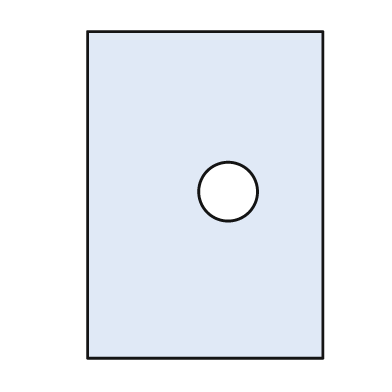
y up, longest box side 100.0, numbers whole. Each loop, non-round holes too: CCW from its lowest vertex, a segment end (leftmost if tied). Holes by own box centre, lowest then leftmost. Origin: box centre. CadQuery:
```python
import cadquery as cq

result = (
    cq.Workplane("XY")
    .moveTo(-36.0, -50.0)
    .lineTo(36.0, -50.0)
    .lineTo(36.0, 50.0)
    .lineTo(-36.0, 50.0)
    .close()
    .moveTo(7.0, 1.0)
    .circle(9.0)
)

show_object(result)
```